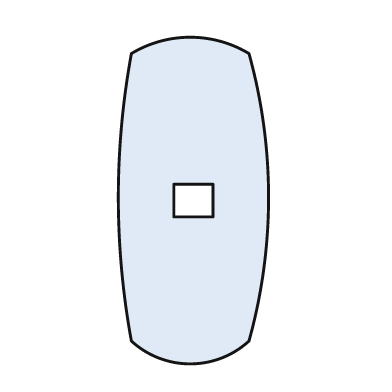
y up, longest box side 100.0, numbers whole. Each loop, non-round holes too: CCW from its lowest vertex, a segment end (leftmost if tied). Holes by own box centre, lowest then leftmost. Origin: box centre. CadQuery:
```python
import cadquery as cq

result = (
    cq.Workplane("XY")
    .moveTo(-19.0, -43.0)
    .threePointArc((-1.0, -50.0), (17.0, -43.0))
    .threePointArc((23.0, 1.0), (17.0, 45.0))
    .threePointArc((-1.0, 50.0), (-19.0, 45.0))
    .threePointArc((-23.0, 1.0), (-19.0, -43.0))
    .close()
    .moveTo(-6.0, -5.0)
    .lineTo(6.0, -5.0)
    .lineTo(6.0, 5.0)
    .lineTo(-6.0, 5.0)
    .close()
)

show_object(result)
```